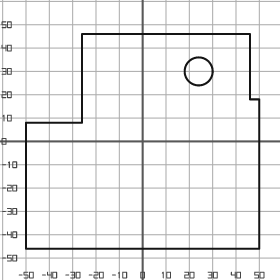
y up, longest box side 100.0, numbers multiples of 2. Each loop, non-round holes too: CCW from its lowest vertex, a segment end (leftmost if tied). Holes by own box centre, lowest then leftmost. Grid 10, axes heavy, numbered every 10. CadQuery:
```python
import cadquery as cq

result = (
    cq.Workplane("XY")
    .moveTo(-50.0, -46.0)
    .lineTo(50.0, -46.0)
    .lineTo(50.0, 18.0)
    .lineTo(46.0, 18.0)
    .lineTo(46.0, 46.0)
    .lineTo(-26.0, 46.0)
    .lineTo(-26.0, 8.0)
    .lineTo(-50.0, 8.0)
    .close()
    .moveTo(24.0, 30.0)
    .circle(6.0)
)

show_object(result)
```